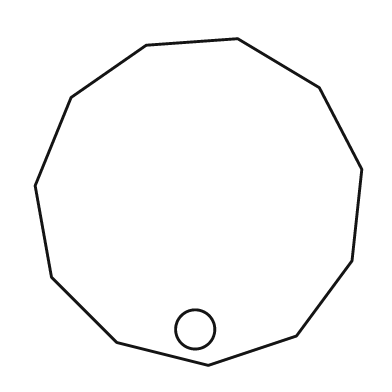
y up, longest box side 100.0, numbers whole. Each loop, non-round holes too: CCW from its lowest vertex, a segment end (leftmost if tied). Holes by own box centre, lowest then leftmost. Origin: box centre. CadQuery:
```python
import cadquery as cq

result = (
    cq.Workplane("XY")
    .moveTo(3.0, -50.0)
    .lineTo(30.0, -41.0)
    .lineTo(47.0, -18.0)
    .lineTo(50.0, 10.0)
    .lineTo(37.0, 35.0)
    .lineTo(12.0, 50.0)
    .lineTo(-16.0, 48.0)
    .lineTo(-39.0, 32.0)
    .lineTo(-50.0, 5.0)
    .lineTo(-45.0, -23.0)
    .lineTo(-25.0, -43.0)
    .close()
    .moveTo(-1.0, -39.0)
    .circle(6.0)
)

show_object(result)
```